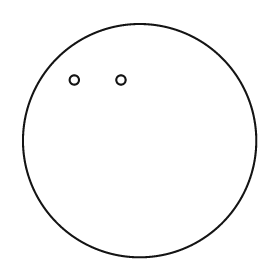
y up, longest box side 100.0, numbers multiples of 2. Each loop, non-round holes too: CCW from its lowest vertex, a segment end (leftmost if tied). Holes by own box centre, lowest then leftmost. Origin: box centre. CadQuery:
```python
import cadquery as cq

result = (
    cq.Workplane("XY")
    .moveTo(0.0, 0.0)
    .circle(50.0)
    .moveTo(-28.0, 26.0)
    .circle(2.0)
    .moveTo(-8.0, 26.0)
    .circle(2.0)
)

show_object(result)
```